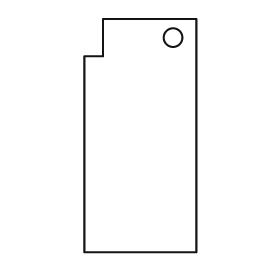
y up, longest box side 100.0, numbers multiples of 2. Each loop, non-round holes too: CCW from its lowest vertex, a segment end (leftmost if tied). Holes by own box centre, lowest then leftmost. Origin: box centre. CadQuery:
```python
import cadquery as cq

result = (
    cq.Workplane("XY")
    .moveTo(-24.0, -50.0)
    .lineTo(24.0, -50.0)
    .lineTo(24.0, 50.0)
    .lineTo(-16.0, 50.0)
    .lineTo(-16.0, 34.0)
    .lineTo(-24.0, 34.0)
    .close()
    .moveTo(14.0, 42.0)
    .circle(4.0)
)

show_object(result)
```